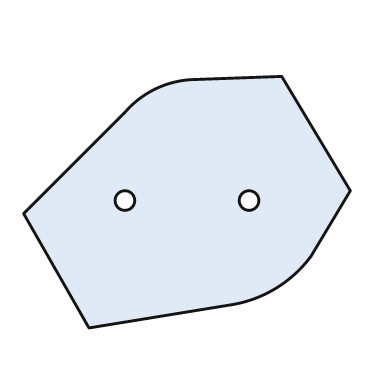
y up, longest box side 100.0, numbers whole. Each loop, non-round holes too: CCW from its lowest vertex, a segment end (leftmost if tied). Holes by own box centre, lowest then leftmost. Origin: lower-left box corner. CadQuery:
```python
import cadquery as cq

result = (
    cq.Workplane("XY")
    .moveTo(20.0, 0.0)
    .lineTo(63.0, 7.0)
    .threePointArc((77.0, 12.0), (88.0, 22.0))
    .lineTo(100.0, 42.0)
    .lineTo(79.0, 77.0)
    .lineTo(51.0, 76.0)
    .threePointArc((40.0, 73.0), (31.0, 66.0))
    .lineTo(0.0, 35.0)
    .close()
    .moveTo(31.0, 39.0)
    .circle(3.0)
    .moveTo(69.0, 39.0)
    .circle(3.0)
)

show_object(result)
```